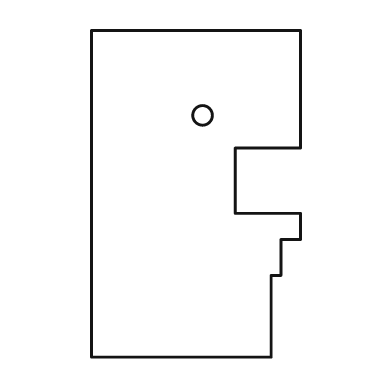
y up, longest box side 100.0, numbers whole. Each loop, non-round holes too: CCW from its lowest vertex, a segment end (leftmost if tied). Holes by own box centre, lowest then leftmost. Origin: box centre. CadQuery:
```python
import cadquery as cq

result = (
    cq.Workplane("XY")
    .moveTo(-32.0, -50.0)
    .lineTo(23.0, -50.0)
    .lineTo(23.0, -25.0)
    .lineTo(26.0, -25.0)
    .lineTo(26.0, -14.0)
    .lineTo(32.0, -14.0)
    .lineTo(32.0, -6.0)
    .lineTo(12.0, -6.0)
    .lineTo(12.0, 14.0)
    .lineTo(32.0, 14.0)
    .lineTo(32.0, 50.0)
    .lineTo(-32.0, 50.0)
    .close()
    .moveTo(2.0, 24.0)
    .circle(3.0)
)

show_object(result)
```